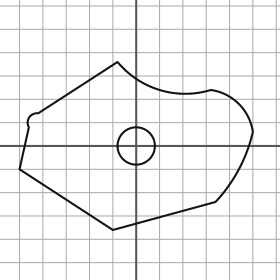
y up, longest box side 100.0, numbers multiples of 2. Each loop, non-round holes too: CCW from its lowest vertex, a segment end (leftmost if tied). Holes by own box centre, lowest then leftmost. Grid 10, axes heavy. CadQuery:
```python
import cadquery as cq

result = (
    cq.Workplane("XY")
    .moveTo(-10.0, -36.0)
    .lineTo(34.0, -24.0)
    .threePointArc((44.0, -10.0), (50.0, 6.0))
    .threePointArc((44.0, 18.0), (32.0, 24.0))
    .threePointArc((10.0, 24.0), (-8.0, 36.0))
    .lineTo(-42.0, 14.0)
    .threePointArc((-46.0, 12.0), (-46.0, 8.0))
    .lineTo(-50.0, -10.0)
    .close()
    .moveTo(0.0, 0.0)
    .circle(8.0)
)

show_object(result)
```